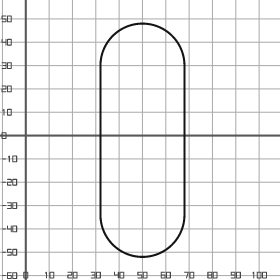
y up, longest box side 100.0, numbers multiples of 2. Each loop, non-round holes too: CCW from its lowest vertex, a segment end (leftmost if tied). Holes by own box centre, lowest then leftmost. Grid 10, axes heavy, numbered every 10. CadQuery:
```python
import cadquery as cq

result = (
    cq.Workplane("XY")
    .moveTo(32.0, -34.0)
    .threePointArc((50.0, -52.0), (68.0, -34.0))
    .lineTo(68.0, 30.0)
    .threePointArc((50.0, 48.0), (32.0, 30.0))
    .close()
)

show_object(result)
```